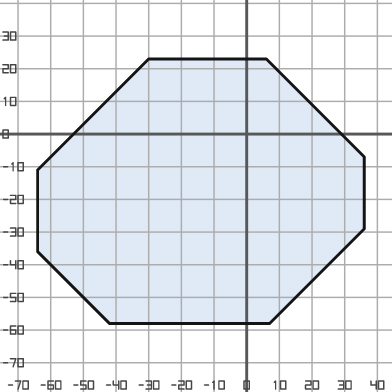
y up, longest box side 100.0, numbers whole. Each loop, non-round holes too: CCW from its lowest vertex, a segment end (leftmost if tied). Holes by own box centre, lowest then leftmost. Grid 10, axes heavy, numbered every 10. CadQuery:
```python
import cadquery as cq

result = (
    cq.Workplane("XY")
    .moveTo(-42.0, -58.0)
    .lineTo(7.0, -58.0)
    .lineTo(36.0, -29.0)
    .lineTo(36.0, -7.0)
    .lineTo(6.0, 23.0)
    .lineTo(-30.0, 23.0)
    .lineTo(-64.0, -11.0)
    .lineTo(-64.0, -36.0)
    .close()
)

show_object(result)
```